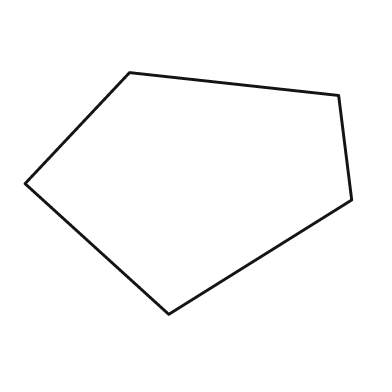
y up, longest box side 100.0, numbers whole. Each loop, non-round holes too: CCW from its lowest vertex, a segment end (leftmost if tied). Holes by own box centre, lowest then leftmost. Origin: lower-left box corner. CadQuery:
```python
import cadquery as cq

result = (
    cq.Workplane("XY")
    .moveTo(44.0, 0.0)
    .lineTo(100.0, 35.0)
    .lineTo(96.0, 67.0)
    .lineTo(32.0, 74.0)
    .lineTo(0.0, 40.0)
    .close()
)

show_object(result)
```